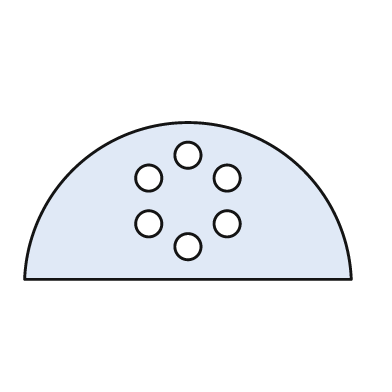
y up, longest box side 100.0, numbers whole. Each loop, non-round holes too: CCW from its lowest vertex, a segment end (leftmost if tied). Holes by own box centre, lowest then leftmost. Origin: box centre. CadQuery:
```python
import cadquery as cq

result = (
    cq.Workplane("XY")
    .moveTo(-50.0, -24.0)
    .lineTo(50.0, -24.0)
    .threePointArc((0.0, 24.0), (-50.0, -24.0))
    .close()
    .moveTo(0.0, -14.0)
    .circle(4.0)
    .moveTo(-12.0, -7.0)
    .circle(4.0)
    .moveTo(12.0, -7.0)
    .circle(4.0)
    .moveTo(-12.0, 7.0)
    .circle(4.0)
    .moveTo(12.0, 7.0)
    .circle(4.0)
    .moveTo(0.0, 14.0)
    .circle(4.0)
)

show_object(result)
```